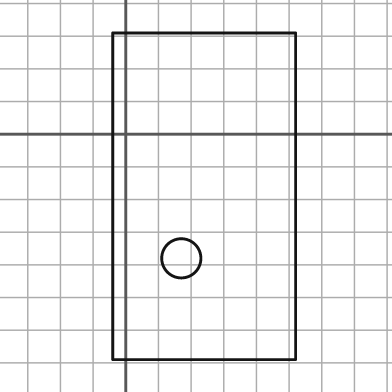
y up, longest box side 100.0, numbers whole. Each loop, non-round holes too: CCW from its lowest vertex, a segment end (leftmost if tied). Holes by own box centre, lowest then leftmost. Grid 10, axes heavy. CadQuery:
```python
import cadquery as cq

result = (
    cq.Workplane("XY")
    .moveTo(-4.0, -69.0)
    .lineTo(52.0, -69.0)
    .lineTo(52.0, 31.0)
    .lineTo(-4.0, 31.0)
    .close()
    .moveTo(17.0, -38.0)
    .circle(6.0)
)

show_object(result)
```